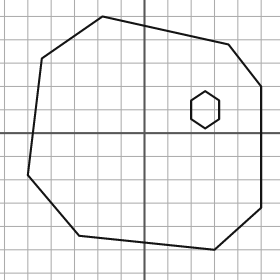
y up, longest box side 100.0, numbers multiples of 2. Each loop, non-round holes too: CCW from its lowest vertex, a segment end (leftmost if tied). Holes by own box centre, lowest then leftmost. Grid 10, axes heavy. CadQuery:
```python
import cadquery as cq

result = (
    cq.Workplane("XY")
    .moveTo(30.0, -50.0)
    .lineTo(50.0, -32.0)
    .lineTo(50.0, 20.0)
    .lineTo(36.0, 38.0)
    .lineTo(-18.0, 50.0)
    .lineTo(-44.0, 32.0)
    .lineTo(-50.0, -18.0)
    .lineTo(-28.0, -44.0)
    .close()
    .moveTo(26.0, 2.0)
    .lineTo(32.0, 6.0)
    .lineTo(32.0, 14.0)
    .lineTo(26.0, 18.0)
    .lineTo(20.0, 14.0)
    .lineTo(20.0, 6.0)
    .close()
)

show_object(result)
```